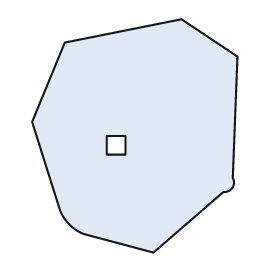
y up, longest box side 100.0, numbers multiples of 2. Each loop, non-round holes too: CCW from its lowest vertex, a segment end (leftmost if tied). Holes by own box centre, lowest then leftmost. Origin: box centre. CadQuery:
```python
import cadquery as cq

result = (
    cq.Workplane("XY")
    .moveTo(8.0, -50.0)
    .lineTo(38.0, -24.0)
    .threePointArc((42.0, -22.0), (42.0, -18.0))
    .lineTo(44.0, 34.0)
    .lineTo(20.0, 50.0)
    .lineTo(-30.0, 40.0)
    .lineTo(-44.0, 6.0)
    .lineTo(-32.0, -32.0)
    .threePointArc((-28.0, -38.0), (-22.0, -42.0))
    .close()
    .moveTo(-12.0, -8.0)
    .lineTo(-4.0, -8.0)
    .lineTo(-4.0, 0.0)
    .lineTo(-12.0, 0.0)
    .close()
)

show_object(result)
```